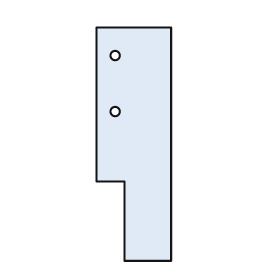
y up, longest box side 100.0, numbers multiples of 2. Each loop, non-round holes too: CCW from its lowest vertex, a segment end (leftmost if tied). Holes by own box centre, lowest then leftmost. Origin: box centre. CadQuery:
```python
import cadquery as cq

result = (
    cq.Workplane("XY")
    .moveTo(-4.0, -50.0)
    .lineTo(16.0, -50.0)
    .lineTo(16.0, 50.0)
    .lineTo(-16.0, 50.0)
    .lineTo(-16.0, -16.0)
    .lineTo(-4.0, -16.0)
    .close()
    .moveTo(-8.0, 14.0)
    .circle(2.0)
    .moveTo(-8.0, 38.0)
    .circle(2.0)
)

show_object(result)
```